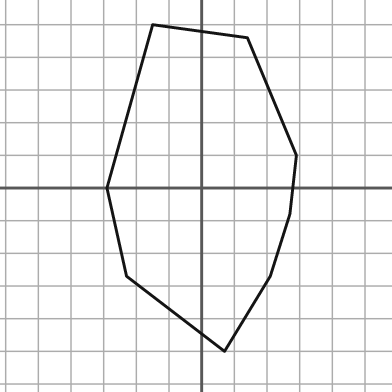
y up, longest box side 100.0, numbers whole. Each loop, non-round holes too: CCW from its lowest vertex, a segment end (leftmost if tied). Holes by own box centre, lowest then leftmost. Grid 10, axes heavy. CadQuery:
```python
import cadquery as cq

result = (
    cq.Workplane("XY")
    .moveTo(7.0, -50.0)
    .lineTo(21.0, -27.0)
    .lineTo(27.0, -8.0)
    .lineTo(29.0, 10.0)
    .lineTo(14.0, 46.0)
    .lineTo(-15.0, 50.0)
    .lineTo(-29.0, 0.0)
    .lineTo(-23.0, -27.0)
    .close()
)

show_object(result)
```